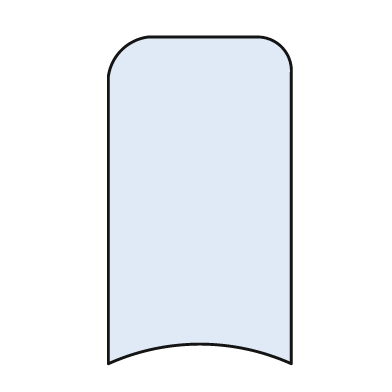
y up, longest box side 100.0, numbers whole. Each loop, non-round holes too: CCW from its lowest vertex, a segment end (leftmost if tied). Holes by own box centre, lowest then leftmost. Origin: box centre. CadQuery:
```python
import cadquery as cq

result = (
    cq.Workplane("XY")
    .moveTo(-28.0, -50.0)
    .threePointArc((0.0, -44.0), (28.0, -50.0))
    .lineTo(28.0, 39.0)
    .threePointArc((25.0, 47.0), (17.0, 50.0))
    .lineTo(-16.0, 50.0)
    .threePointArc((-24.0, 46.0), (-28.0, 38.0))
    .close()
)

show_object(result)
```